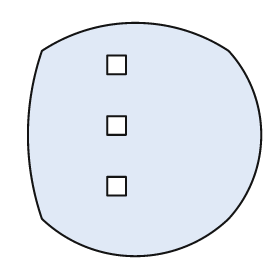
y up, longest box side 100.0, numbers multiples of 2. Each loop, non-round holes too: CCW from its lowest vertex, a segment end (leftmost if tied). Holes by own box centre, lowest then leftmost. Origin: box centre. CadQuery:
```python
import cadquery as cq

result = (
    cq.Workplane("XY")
    .moveTo(-44.0, -34.0)
    .threePointArc((-4.0, -50.0), (36.0, -34.0))
    .threePointArc((50.0, 2.0), (36.0, 38.0))
    .threePointArc((-4.0, 50.0), (-44.0, 38.0))
    .threePointArc((-50.0, 2.0), (-44.0, -34.0))
    .close()
    .moveTo(-16.0, -24.0)
    .lineTo(-8.0, -24.0)
    .lineTo(-8.0, -16.0)
    .lineTo(-16.0, -16.0)
    .close()
    .moveTo(-16.0, 2.0)
    .lineTo(-8.0, 2.0)
    .lineTo(-8.0, 10.0)
    .lineTo(-16.0, 10.0)
    .close()
    .moveTo(-16.0, 28.0)
    .lineTo(-8.0, 28.0)
    .lineTo(-8.0, 36.0)
    .lineTo(-16.0, 36.0)
    .close()
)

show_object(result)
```